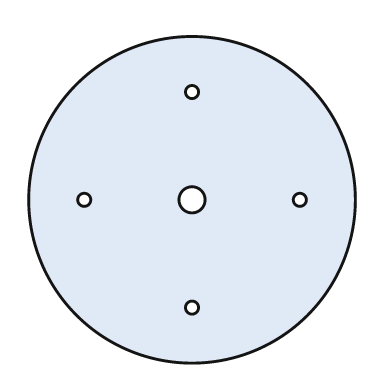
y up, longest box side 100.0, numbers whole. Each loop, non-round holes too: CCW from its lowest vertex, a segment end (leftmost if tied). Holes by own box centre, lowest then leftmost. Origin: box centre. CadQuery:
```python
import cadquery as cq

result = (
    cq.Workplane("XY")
    .moveTo(0.0, 0.0)
    .circle(50.0)
    .moveTo(0.0, -33.0)
    .circle(2.0)
    .moveTo(-33.0, 0.0)
    .circle(2.0)
    .moveTo(0.0, 0.0)
    .circle(4.0)
    .moveTo(33.0, 0.0)
    .circle(2.0)
    .moveTo(0.0, 33.0)
    .circle(2.0)
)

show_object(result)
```